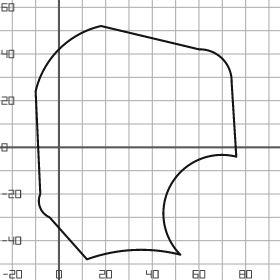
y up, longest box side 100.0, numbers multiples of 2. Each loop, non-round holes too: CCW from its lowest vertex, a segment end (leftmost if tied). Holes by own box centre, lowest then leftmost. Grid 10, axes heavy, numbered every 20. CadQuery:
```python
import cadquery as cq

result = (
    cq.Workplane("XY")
    .moveTo(12.0, -48.0)
    .threePointArc((32.0, -44.0), (52.0, -46.0))
    .threePointArc((48.0, -16.0), (76.0, -4.0))
    .lineTo(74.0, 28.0)
    .threePointArc((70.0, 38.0), (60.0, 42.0))
    .lineTo(18.0, 52.0)
    .threePointArc((0.0, 42.0), (-10.0, 24.0))
    .lineTo(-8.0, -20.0)
    .threePointArc((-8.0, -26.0), (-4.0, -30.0))
    .close()
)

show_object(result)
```